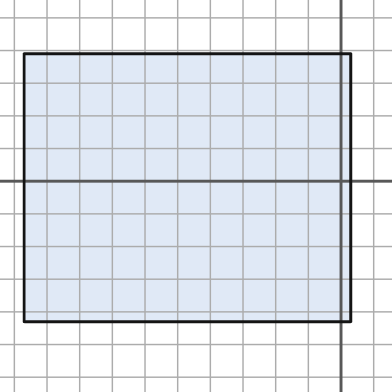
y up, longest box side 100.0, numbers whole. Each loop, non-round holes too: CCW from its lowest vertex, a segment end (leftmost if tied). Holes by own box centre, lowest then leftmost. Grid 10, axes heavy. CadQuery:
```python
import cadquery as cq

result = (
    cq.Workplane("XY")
    .moveTo(-97.0, -43.0)
    .lineTo(3.0, -43.0)
    .lineTo(3.0, 39.0)
    .lineTo(-97.0, 39.0)
    .close()
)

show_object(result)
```